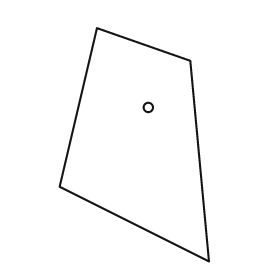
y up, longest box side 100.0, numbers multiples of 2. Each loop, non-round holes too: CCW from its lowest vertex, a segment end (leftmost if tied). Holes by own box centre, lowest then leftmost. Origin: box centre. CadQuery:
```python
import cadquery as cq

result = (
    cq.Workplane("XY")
    .moveTo(32.0, -50.0)
    .lineTo(24.0, 36.0)
    .lineTo(-16.0, 50.0)
    .lineTo(-32.0, -18.0)
    .close()
    .moveTo(6.0, 16.0)
    .circle(2.0)
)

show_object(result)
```